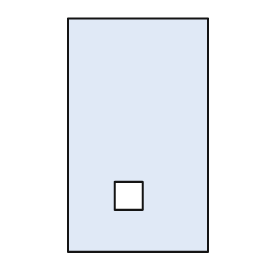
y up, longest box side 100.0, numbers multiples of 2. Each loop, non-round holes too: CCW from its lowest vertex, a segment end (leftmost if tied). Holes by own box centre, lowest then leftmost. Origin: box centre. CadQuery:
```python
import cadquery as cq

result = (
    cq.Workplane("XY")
    .moveTo(-30.0, -50.0)
    .lineTo(30.0, -50.0)
    .lineTo(30.0, 50.0)
    .lineTo(-30.0, 50.0)
    .close()
    .moveTo(-10.0, -32.0)
    .lineTo(2.0, -32.0)
    .lineTo(2.0, -20.0)
    .lineTo(-10.0, -20.0)
    .close()
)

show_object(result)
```